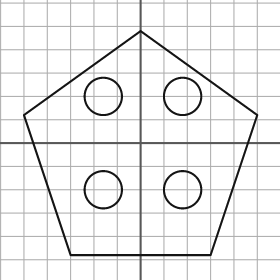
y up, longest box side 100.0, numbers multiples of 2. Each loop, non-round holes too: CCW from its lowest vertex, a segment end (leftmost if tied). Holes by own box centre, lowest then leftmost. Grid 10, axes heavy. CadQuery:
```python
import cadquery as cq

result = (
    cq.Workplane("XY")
    .moveTo(-30.0, -48.0)
    .lineTo(30.0, -48.0)
    .lineTo(50.0, 12.0)
    .lineTo(0.0, 48.0)
    .lineTo(-50.0, 12.0)
    .close()
    .moveTo(-16.0, -20.0)
    .circle(8.0)
    .moveTo(18.0, -20.0)
    .circle(8.0)
    .moveTo(-16.0, 20.0)
    .circle(8.0)
    .moveTo(18.0, 20.0)
    .circle(8.0)
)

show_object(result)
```